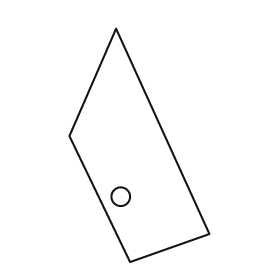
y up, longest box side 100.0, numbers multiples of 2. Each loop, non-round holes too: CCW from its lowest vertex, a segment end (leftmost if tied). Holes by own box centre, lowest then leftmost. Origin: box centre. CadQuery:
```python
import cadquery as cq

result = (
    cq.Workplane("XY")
    .moveTo(-4.0, -50.0)
    .lineTo(30.0, -38.0)
    .lineTo(-10.0, 50.0)
    .lineTo(-30.0, 4.0)
    .close()
    .moveTo(-8.0, -22.0)
    .circle(4.0)
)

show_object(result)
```